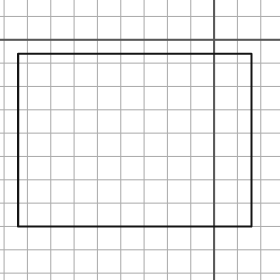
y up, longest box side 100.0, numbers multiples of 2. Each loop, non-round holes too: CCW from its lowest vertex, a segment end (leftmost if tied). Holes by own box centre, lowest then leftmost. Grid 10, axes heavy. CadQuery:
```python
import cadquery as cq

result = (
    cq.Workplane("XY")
    .moveTo(-84.0, -80.0)
    .lineTo(16.0, -80.0)
    .lineTo(16.0, -6.0)
    .lineTo(-84.0, -6.0)
    .close()
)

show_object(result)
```